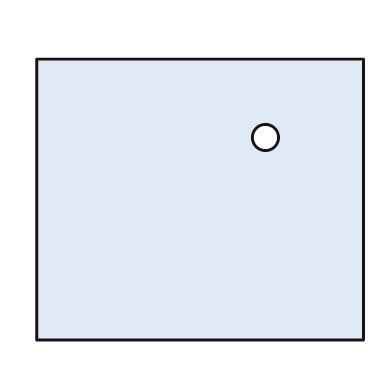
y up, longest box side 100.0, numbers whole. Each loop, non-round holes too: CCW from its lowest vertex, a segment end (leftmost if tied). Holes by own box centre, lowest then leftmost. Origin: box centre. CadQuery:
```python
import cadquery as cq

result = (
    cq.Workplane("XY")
    .moveTo(-50.0, -43.0)
    .lineTo(50.0, -43.0)
    .lineTo(50.0, 43.0)
    .lineTo(-50.0, 43.0)
    .close()
    .moveTo(20.0, 19.0)
    .circle(4.0)
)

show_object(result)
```